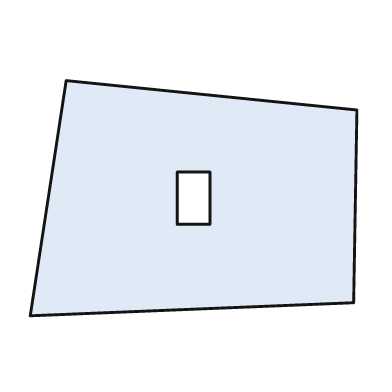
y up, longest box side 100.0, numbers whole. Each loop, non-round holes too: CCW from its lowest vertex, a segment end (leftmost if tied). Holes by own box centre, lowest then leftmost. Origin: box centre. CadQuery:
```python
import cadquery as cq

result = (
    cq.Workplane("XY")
    .moveTo(-50.0, -36.0)
    .lineTo(49.0, -32.0)
    .lineTo(50.0, 27.0)
    .lineTo(-39.0, 36.0)
    .close()
    .moveTo(-5.0, -8.0)
    .lineTo(5.0, -8.0)
    .lineTo(5.0, 8.0)
    .lineTo(-5.0, 8.0)
    .close()
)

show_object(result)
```